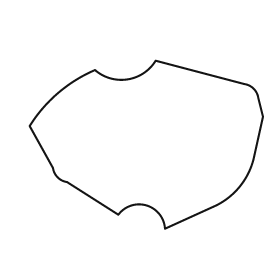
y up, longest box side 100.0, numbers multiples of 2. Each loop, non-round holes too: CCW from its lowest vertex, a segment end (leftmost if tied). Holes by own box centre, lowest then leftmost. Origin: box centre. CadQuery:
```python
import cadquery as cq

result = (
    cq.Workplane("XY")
    .moveTo(8.0, -36.0)
    .lineTo(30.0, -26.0)
    .threePointArc((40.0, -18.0), (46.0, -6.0))
    .lineTo(50.0, 12.0)
    .lineTo(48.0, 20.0)
    .threePointArc((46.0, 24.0), (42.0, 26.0))
    .lineTo(4.0, 36.0)
    .threePointArc((-8.0, 28.0), (-22.0, 32.0))
    .threePointArc((-38.0, 22.0), (-50.0, 8.0))
    .lineTo(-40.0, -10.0)
    .threePointArc((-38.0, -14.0), (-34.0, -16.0))
    .lineTo(-12.0, -30.0)
    .threePointArc((0.0, -26.0), (8.0, -36.0))
    .close()
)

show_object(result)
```